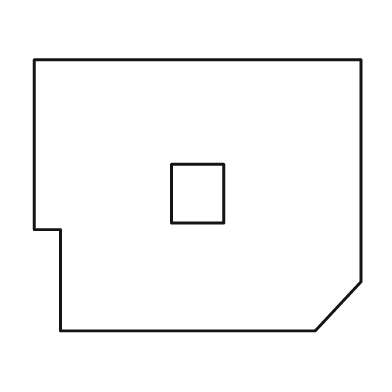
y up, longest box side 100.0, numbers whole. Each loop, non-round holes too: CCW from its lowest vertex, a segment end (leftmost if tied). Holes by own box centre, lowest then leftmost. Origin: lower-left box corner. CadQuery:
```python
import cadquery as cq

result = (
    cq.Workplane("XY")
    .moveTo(8.0, 0.0)
    .lineTo(86.0, 0.0)
    .lineTo(100.0, 15.0)
    .lineTo(100.0, 83.0)
    .lineTo(0.0, 83.0)
    .lineTo(0.0, 31.0)
    .lineTo(8.0, 31.0)
    .close()
    .moveTo(42.0, 33.0)
    .lineTo(58.0, 33.0)
    .lineTo(58.0, 51.0)
    .lineTo(42.0, 51.0)
    .close()
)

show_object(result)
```